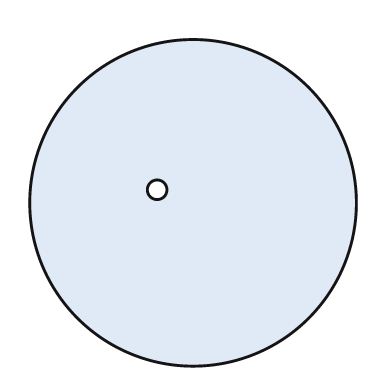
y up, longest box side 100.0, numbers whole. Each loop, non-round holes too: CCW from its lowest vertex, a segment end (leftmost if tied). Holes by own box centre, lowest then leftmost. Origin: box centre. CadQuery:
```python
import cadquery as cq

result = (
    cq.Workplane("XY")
    .moveTo(0.0, 0.0)
    .circle(50.0)
    .moveTo(-11.0, 4.0)
    .circle(3.0)
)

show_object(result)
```